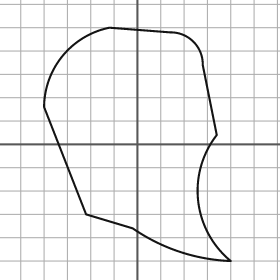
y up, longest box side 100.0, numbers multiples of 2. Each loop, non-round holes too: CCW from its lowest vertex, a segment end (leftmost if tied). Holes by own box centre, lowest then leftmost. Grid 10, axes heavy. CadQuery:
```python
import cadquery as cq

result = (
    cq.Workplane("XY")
    .moveTo(40.0, -50.0)
    .threePointArc((26.0, -24.0), (34.0, 4.0))
    .lineTo(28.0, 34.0)
    .threePointArc((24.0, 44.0), (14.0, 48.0))
    .lineTo(-12.0, 50.0)
    .threePointArc((-32.0, 38.0), (-40.0, 16.0))
    .lineTo(-22.0, -30.0)
    .lineTo(-2.0, -36.0)
    .threePointArc((18.0, -46.0), (40.0, -50.0))
    .close()
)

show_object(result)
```